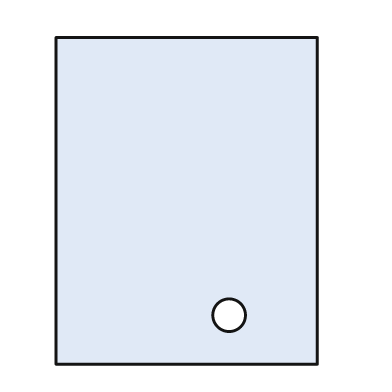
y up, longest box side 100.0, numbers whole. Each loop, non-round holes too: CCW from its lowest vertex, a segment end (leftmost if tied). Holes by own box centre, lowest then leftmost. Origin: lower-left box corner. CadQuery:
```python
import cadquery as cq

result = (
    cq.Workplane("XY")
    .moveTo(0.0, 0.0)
    .lineTo(80.0, 0.0)
    .lineTo(80.0, 100.0)
    .lineTo(0.0, 100.0)
    .close()
    .moveTo(53.0, 15.0)
    .circle(5.0)
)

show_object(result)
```